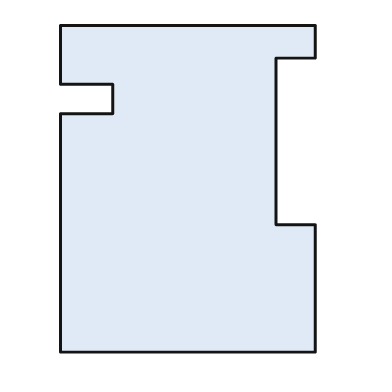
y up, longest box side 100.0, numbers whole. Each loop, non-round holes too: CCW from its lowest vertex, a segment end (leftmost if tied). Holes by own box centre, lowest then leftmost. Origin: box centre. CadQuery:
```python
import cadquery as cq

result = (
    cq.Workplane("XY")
    .moveTo(-39.0, -50.0)
    .lineTo(39.0, -50.0)
    .lineTo(39.0, -11.0)
    .lineTo(27.0, -11.0)
    .lineTo(27.0, 40.0)
    .lineTo(39.0, 40.0)
    .lineTo(39.0, 50.0)
    .lineTo(-39.0, 50.0)
    .lineTo(-39.0, 32.0)
    .lineTo(-23.0, 32.0)
    .lineTo(-23.0, 23.0)
    .lineTo(-39.0, 23.0)
    .close()
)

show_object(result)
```